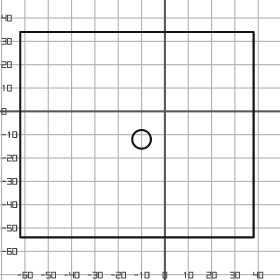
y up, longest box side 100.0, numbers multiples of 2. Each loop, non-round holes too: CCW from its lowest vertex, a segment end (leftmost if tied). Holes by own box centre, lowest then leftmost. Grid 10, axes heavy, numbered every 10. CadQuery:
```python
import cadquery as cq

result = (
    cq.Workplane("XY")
    .moveTo(-62.0, -54.0)
    .lineTo(38.0, -54.0)
    .lineTo(38.0, 34.0)
    .lineTo(-62.0, 34.0)
    .close()
    .moveTo(-10.0, -12.0)
    .circle(4.0)
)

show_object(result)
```